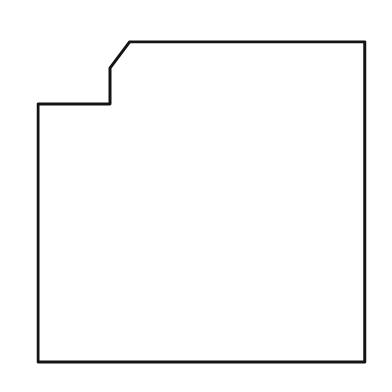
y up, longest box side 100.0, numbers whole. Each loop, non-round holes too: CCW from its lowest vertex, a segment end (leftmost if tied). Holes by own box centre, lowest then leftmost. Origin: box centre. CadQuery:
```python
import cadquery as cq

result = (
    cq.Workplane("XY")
    .moveTo(-50.0, -49.0)
    .lineTo(50.0, -49.0)
    .lineTo(50.0, 49.0)
    .lineTo(-22.0, 49.0)
    .lineTo(-28.0, 41.0)
    .lineTo(-28.0, 30.0)
    .lineTo(-50.0, 30.0)
    .close()
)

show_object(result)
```